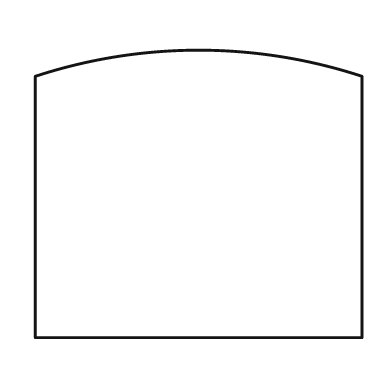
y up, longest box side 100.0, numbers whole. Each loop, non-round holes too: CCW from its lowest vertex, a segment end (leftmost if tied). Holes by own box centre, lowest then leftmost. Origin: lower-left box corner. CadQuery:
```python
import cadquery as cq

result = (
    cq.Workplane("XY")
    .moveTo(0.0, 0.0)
    .lineTo(100.0, 0.0)
    .lineTo(100.0, 80.0)
    .threePointArc((50.0, 88.0), (0.0, 80.0))
    .close()
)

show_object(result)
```